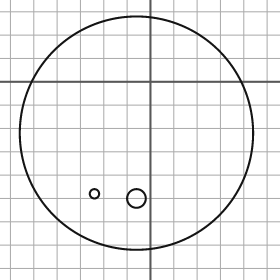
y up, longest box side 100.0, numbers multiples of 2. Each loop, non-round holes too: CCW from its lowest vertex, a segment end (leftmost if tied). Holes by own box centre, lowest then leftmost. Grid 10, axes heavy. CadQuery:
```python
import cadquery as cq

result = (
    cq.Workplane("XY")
    .moveTo(-6.0, -22.0)
    .circle(50.0)
    .moveTo(-6.0, -50.0)
    .circle(4.0)
    .moveTo(-24.0, -48.0)
    .circle(2.0)
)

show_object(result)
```